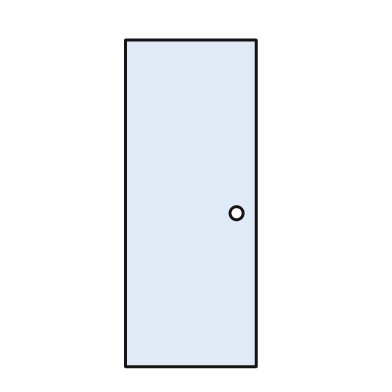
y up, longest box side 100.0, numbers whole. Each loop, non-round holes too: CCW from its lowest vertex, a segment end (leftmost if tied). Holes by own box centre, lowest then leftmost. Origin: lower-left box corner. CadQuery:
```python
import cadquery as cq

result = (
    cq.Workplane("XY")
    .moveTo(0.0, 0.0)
    .lineTo(40.0, 0.0)
    .lineTo(40.0, 100.0)
    .lineTo(0.0, 100.0)
    .close()
    .moveTo(34.0, 47.0)
    .circle(2.0)
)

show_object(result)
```